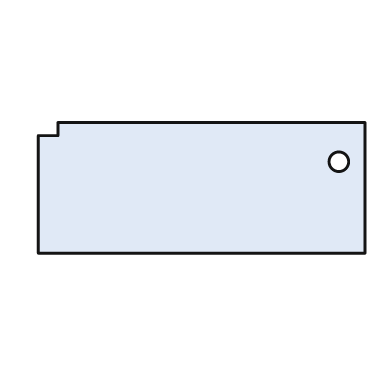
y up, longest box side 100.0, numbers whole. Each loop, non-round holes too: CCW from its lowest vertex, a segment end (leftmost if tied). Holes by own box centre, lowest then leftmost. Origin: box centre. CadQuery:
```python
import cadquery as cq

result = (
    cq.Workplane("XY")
    .moveTo(-50.0, -20.0)
    .lineTo(50.0, -20.0)
    .lineTo(50.0, 20.0)
    .lineTo(-44.0, 20.0)
    .lineTo(-44.0, 16.0)
    .lineTo(-50.0, 16.0)
    .close()
    .moveTo(42.0, 8.0)
    .circle(3.0)
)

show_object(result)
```